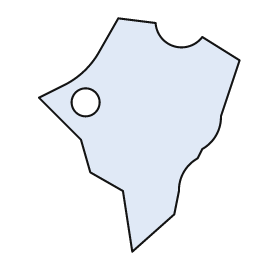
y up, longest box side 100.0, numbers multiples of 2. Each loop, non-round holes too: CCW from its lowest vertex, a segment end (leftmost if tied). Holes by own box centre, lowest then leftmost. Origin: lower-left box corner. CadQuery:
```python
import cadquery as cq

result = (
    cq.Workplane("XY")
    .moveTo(40.0, 0.0)
    .lineTo(58.0, 16.0)
    .lineTo(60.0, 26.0)
    .threePointArc((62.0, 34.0), (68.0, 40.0))
    .lineTo(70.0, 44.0)
    .threePointArc((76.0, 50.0), (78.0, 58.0))
    .lineTo(86.0, 82.0)
    .lineTo(70.0, 92.0)
    .threePointArc((58.0, 88.0), (50.0, 98.0))
    .lineTo(34.0, 100.0)
    .lineTo(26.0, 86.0)
    .threePointArc((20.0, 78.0), (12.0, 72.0))
    .lineTo(0.0, 66.0)
    .lineTo(18.0, 48.0)
    .lineTo(22.0, 34.0)
    .lineTo(36.0, 26.0)
    .close()
    .moveTo(20.0, 64.0)
    .circle(6.0)
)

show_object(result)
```